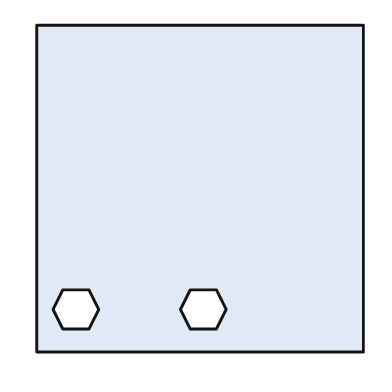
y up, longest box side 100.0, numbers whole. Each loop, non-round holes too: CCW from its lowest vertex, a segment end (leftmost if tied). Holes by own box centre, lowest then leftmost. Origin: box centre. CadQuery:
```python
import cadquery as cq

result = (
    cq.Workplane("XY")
    .moveTo(-50.0, -50.0)
    .lineTo(50.0, -50.0)
    .lineTo(50.0, 50.0)
    .lineTo(-50.0, 50.0)
    .close()
    .moveTo(-42.0, -43.0)
    .lineTo(-34.0, -43.0)
    .lineTo(-31.0, -37.0)
    .lineTo(-34.0, -31.0)
    .lineTo(-42.0, -31.0)
    .lineTo(-45.0, -37.0)
    .close()
    .moveTo(-3.0, -43.0)
    .lineTo(5.0, -43.0)
    .lineTo(8.0, -37.0)
    .lineTo(5.0, -31.0)
    .lineTo(-3.0, -31.0)
    .lineTo(-6.0, -37.0)
    .close()
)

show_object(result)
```